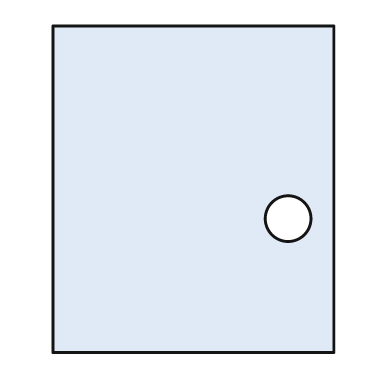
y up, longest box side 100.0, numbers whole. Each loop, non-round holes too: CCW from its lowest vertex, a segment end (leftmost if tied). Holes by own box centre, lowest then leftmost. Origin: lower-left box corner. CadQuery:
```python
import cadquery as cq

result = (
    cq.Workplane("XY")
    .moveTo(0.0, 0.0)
    .lineTo(86.0, 0.0)
    .lineTo(86.0, 100.0)
    .lineTo(0.0, 100.0)
    .close()
    .moveTo(72.0, 41.0)
    .circle(7.0)
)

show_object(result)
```